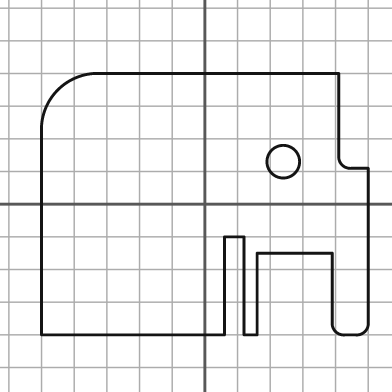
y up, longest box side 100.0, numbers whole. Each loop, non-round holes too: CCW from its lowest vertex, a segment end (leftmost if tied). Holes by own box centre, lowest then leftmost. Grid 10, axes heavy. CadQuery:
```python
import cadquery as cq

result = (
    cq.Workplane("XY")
    .moveTo(-50.0, -40.0)
    .lineTo(6.0, -40.0)
    .lineTo(6.0, -10.0)
    .lineTo(12.0, -10.0)
    .lineTo(12.0, -40.0)
    .lineTo(16.0, -40.0)
    .lineTo(16.0, -15.0)
    .lineTo(39.0, -15.0)
    .lineTo(39.0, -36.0)
    .threePointArc((40.0, -39.0), (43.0, -40.0))
    .lineTo(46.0, -40.0)
    .threePointArc((49.0, -39.0), (50.0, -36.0))
    .lineTo(50.0, 11.0)
    .lineTo(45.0, 11.0)
    .threePointArc((42.0, 12.0), (41.0, 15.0))
    .lineTo(41.0, 40.0)
    .lineTo(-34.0, 40.0)
    .threePointArc((-45.0, 35.0), (-50.0, 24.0))
    .close()
    .moveTo(24.0, 13.0)
    .circle(5.0)
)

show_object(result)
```